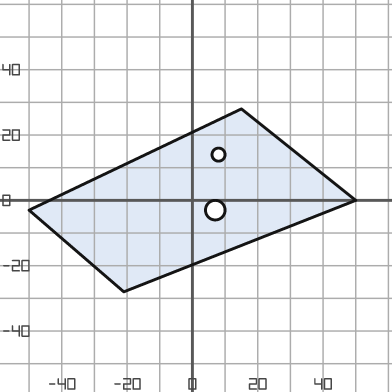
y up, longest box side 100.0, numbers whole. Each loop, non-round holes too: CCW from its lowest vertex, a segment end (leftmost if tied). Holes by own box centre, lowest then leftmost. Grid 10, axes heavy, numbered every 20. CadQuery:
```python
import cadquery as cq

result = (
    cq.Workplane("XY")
    .moveTo(-21.0, -28.0)
    .lineTo(50.0, 0.0)
    .lineTo(15.0, 28.0)
    .lineTo(-50.0, -3.0)
    .close()
    .moveTo(7.0, -3.0)
    .circle(3.0)
    .moveTo(8.0, 14.0)
    .circle(2.0)
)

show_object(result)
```